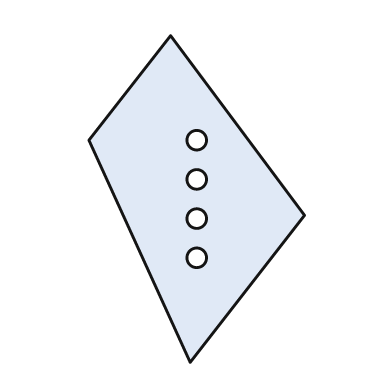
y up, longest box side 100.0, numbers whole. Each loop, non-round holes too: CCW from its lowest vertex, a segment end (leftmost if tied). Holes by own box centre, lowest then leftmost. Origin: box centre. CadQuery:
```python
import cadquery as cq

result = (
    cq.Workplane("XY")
    .moveTo(-2.0, -50.0)
    .lineTo(33.0, -5.0)
    .lineTo(-8.0, 50.0)
    .lineTo(-33.0, 18.0)
    .close()
    .moveTo(0.0, -18.0)
    .circle(3.0)
    .moveTo(0.0, -6.0)
    .circle(3.0)
    .moveTo(0.0, 6.0)
    .circle(3.0)
    .moveTo(0.0, 18.0)
    .circle(3.0)
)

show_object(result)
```